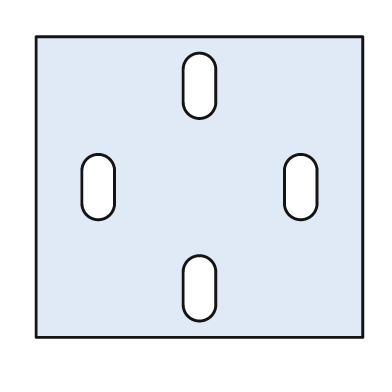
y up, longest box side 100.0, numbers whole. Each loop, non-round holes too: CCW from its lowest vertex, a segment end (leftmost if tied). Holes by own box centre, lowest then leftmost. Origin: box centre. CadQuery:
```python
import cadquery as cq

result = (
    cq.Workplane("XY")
    .moveTo(-50.0, -46.0)
    .lineTo(50.0, -46.0)
    .lineTo(50.0, 46.0)
    .lineTo(-50.0, 46.0)
    .close()
    .moveTo(-5.0, -36.0)
    .threePointArc((0.0, -41.0), (5.0, -36.0))
    .lineTo(5.0, -26.0)
    .threePointArc((0.0, -21.0), (-5.0, -26.0))
    .close()
    .moveTo(-36.0, -5.0)
    .threePointArc((-31.0, -10.0), (-26.0, -5.0))
    .lineTo(-26.0, 5.0)
    .threePointArc((-31.0, 10.0), (-36.0, 5.0))
    .close()
    .moveTo(26.0, -5.0)
    .threePointArc((31.0, -10.0), (36.0, -5.0))
    .lineTo(36.0, 5.0)
    .threePointArc((31.0, 10.0), (26.0, 5.0))
    .close()
    .moveTo(-5.0, 26.0)
    .threePointArc((0.0, 21.0), (5.0, 26.0))
    .lineTo(5.0, 36.0)
    .threePointArc((0.0, 41.0), (-5.0, 36.0))
    .close()
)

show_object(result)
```